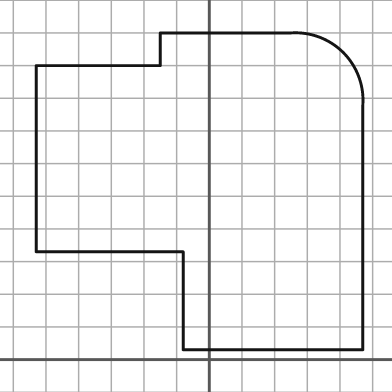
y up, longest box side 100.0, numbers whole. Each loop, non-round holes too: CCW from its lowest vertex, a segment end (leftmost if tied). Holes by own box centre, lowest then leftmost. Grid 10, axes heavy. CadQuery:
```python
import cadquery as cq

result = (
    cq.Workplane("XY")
    .moveTo(-8.0, 3.0)
    .lineTo(47.0, 3.0)
    .lineTo(47.0, 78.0)
    .threePointArc((41.0, 94.0), (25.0, 100.0))
    .lineTo(-15.0, 100.0)
    .lineTo(-15.0, 90.0)
    .lineTo(-53.0, 90.0)
    .lineTo(-53.0, 33.0)
    .lineTo(-8.0, 33.0)
    .close()
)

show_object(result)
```